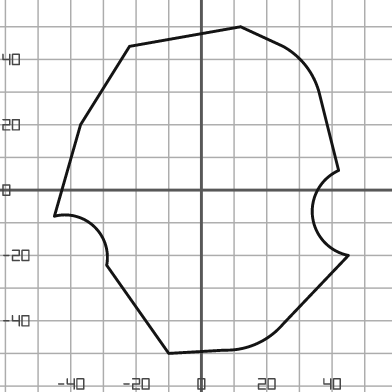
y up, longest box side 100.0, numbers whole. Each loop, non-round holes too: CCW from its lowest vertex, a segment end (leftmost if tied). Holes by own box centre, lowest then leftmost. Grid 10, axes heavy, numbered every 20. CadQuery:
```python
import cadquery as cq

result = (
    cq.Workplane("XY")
    .moveTo(-10.0, -50.0)
    .lineTo(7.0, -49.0)
    .threePointArc((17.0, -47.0), (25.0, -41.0))
    .lineTo(45.0, -20.0)
    .threePointArc((34.0, -8.0), (42.0, 6.0))
    .lineTo(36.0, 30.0)
    .threePointArc((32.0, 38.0), (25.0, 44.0))
    .lineTo(12.0, 50.0)
    .lineTo(-22.0, 44.0)
    .lineTo(-37.0, 20.0)
    .lineTo(-45.0, -8.0)
    .threePointArc((-33.0, -11.0), (-29.0, -23.0))
    .close()
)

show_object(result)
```